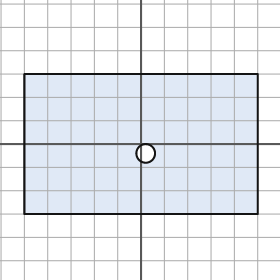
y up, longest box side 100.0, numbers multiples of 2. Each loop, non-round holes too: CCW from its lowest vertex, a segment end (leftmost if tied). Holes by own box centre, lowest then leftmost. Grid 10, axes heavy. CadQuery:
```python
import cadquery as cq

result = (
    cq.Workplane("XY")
    .moveTo(-50.0, -30.0)
    .lineTo(50.0, -30.0)
    .lineTo(50.0, 30.0)
    .lineTo(-50.0, 30.0)
    .close()
    .moveTo(2.0, -4.0)
    .circle(4.0)
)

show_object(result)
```